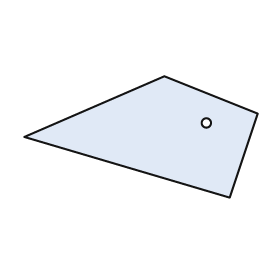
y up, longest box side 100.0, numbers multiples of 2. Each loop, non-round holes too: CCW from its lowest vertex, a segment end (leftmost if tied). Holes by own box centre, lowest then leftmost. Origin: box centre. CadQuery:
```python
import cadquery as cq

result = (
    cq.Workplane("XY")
    .moveTo(38.0, -26.0)
    .lineTo(50.0, 10.0)
    .lineTo(10.0, 26.0)
    .lineTo(-50.0, 0.0)
    .close()
    .moveTo(28.0, 6.0)
    .circle(2.0)
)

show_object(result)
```